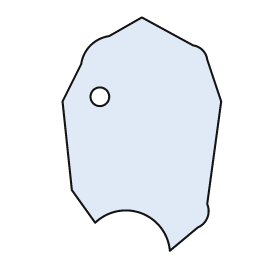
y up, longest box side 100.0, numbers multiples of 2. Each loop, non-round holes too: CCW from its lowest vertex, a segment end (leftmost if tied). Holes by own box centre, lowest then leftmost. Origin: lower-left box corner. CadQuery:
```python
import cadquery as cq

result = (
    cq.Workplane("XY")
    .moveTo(46.0, 0.0)
    .lineTo(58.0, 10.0)
    .threePointArc((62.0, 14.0), (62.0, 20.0))
    .lineTo(68.0, 64.0)
    .lineTo(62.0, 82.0)
    .threePointArc((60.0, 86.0), (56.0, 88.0))
    .lineTo(34.0, 100.0)
    .lineTo(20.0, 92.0)
    .threePointArc((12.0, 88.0), (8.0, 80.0))
    .lineTo(0.0, 64.0)
    .lineTo(4.0, 26.0)
    .lineTo(14.0, 12.0)
    .threePointArc((34.0, 16.0), (46.0, 0.0))
    .close()
    .moveTo(16.0, 66.0)
    .circle(4.0)
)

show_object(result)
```